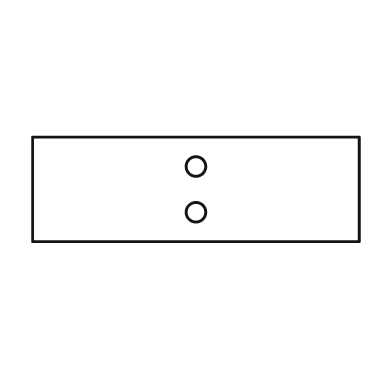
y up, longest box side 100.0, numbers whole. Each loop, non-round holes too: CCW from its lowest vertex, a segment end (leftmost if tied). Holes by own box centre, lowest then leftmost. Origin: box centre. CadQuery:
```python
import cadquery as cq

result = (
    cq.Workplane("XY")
    .moveTo(-50.0, -16.0)
    .lineTo(50.0, -16.0)
    .lineTo(50.0, 16.0)
    .lineTo(-50.0, 16.0)
    .close()
    .moveTo(0.0, -7.0)
    .circle(3.0)
    .moveTo(0.0, 7.0)
    .circle(3.0)
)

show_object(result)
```